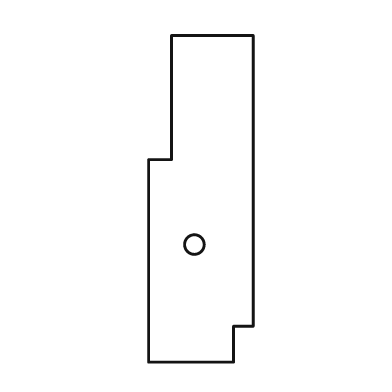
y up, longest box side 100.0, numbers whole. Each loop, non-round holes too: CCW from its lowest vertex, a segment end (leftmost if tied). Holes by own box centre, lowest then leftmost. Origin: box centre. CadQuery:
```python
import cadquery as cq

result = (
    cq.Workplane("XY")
    .moveTo(-16.0, -50.0)
    .lineTo(10.0, -50.0)
    .lineTo(10.0, -39.0)
    .lineTo(16.0, -39.0)
    .lineTo(16.0, 50.0)
    .lineTo(-9.0, 50.0)
    .lineTo(-9.0, 12.0)
    .lineTo(-16.0, 12.0)
    .close()
    .moveTo(-2.0, -14.0)
    .circle(3.0)
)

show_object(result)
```